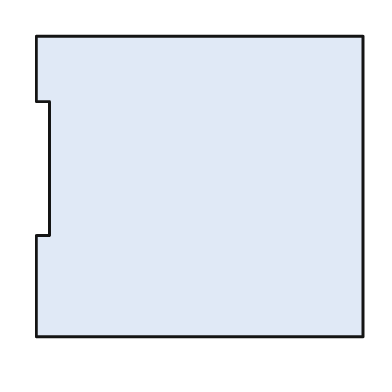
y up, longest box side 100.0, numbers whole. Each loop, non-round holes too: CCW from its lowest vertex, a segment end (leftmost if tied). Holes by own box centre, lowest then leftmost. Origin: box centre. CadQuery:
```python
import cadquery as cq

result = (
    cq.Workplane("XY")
    .moveTo(-50.0, -46.0)
    .lineTo(50.0, -46.0)
    .lineTo(50.0, 46.0)
    .lineTo(-50.0, 46.0)
    .lineTo(-50.0, 26.0)
    .lineTo(-46.0, 26.0)
    .lineTo(-46.0, -15.0)
    .lineTo(-50.0, -15.0)
    .close()
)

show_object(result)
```